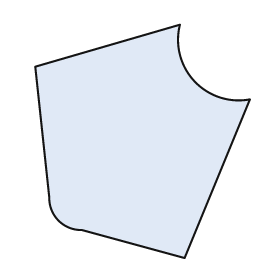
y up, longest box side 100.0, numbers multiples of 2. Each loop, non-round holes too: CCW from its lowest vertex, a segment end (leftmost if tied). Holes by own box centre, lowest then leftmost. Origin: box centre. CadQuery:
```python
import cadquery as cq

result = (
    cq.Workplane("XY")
    .moveTo(18.0, -50.0)
    .lineTo(46.0, 18.0)
    .threePointArc((22.0, 26.0), (16.0, 50.0))
    .lineTo(-46.0, 32.0)
    .lineTo(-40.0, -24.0)
    .threePointArc((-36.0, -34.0), (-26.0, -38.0))
    .close()
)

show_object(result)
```